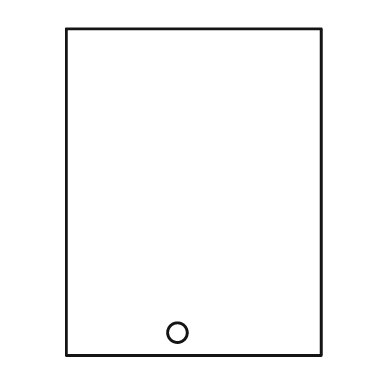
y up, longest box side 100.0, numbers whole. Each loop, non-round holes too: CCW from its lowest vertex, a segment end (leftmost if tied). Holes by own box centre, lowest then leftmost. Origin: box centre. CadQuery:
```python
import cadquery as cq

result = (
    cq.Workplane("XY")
    .moveTo(-39.0, -50.0)
    .lineTo(39.0, -50.0)
    .lineTo(39.0, 50.0)
    .lineTo(-39.0, 50.0)
    .close()
    .moveTo(-5.0, -43.0)
    .circle(3.0)
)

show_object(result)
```